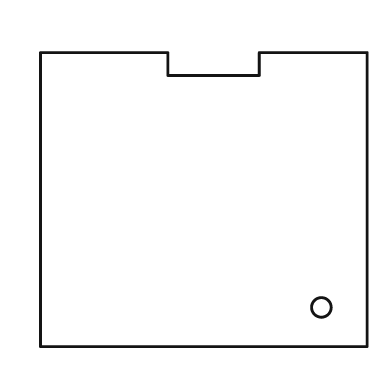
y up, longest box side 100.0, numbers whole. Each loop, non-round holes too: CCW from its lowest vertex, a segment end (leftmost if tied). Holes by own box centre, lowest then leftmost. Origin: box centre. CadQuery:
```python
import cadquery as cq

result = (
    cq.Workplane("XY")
    .moveTo(-50.0, -45.0)
    .lineTo(50.0, -45.0)
    .lineTo(50.0, 45.0)
    .lineTo(17.0, 45.0)
    .lineTo(17.0, 38.0)
    .lineTo(-11.0, 38.0)
    .lineTo(-11.0, 45.0)
    .lineTo(-50.0, 45.0)
    .close()
    .moveTo(36.0, -33.0)
    .circle(3.0)
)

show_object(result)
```